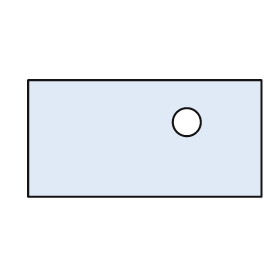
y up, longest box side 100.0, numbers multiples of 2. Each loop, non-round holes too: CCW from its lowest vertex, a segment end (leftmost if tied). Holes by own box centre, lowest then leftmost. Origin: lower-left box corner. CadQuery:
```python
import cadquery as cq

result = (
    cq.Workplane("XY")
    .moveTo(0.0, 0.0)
    .lineTo(100.0, 0.0)
    .lineTo(100.0, 50.0)
    .lineTo(0.0, 50.0)
    .close()
    .moveTo(68.0, 32.0)
    .circle(6.0)
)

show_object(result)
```